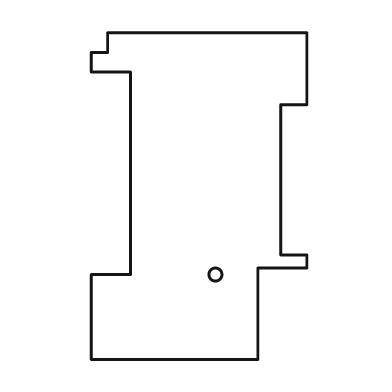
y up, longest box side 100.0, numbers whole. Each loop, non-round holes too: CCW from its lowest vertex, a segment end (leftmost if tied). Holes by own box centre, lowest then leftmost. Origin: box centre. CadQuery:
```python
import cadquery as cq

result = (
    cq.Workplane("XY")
    .moveTo(-33.0, -50.0)
    .lineTo(18.0, -50.0)
    .lineTo(18.0, -22.0)
    .lineTo(33.0, -22.0)
    .lineTo(33.0, -18.0)
    .lineTo(25.0, -18.0)
    .lineTo(25.0, 28.0)
    .lineTo(33.0, 28.0)
    .lineTo(33.0, 50.0)
    .lineTo(-28.0, 50.0)
    .lineTo(-28.0, 44.0)
    .lineTo(-33.0, 44.0)
    .lineTo(-33.0, 38.0)
    .lineTo(-21.0, 38.0)
    .lineTo(-21.0, -24.0)
    .lineTo(-33.0, -24.0)
    .close()
    .moveTo(5.0, -24.0)
    .circle(2.0)
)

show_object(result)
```